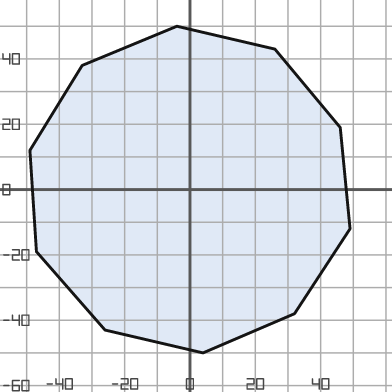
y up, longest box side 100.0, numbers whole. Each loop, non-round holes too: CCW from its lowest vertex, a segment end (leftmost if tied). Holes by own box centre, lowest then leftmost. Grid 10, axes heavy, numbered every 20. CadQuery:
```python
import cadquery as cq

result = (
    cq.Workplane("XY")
    .moveTo(4.0, -50.0)
    .lineTo(32.0, -38.0)
    .lineTo(49.0, -12.0)
    .lineTo(46.0, 19.0)
    .lineTo(26.0, 43.0)
    .lineTo(-4.0, 50.0)
    .lineTo(-33.0, 38.0)
    .lineTo(-49.0, 12.0)
    .lineTo(-47.0, -19.0)
    .lineTo(-26.0, -43.0)
    .close()
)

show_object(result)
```